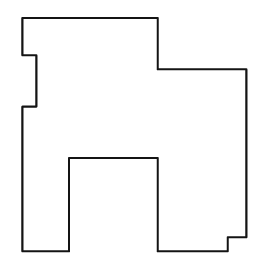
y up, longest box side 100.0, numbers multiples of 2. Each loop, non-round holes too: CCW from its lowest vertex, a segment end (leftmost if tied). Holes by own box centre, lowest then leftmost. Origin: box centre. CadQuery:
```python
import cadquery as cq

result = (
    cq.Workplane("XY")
    .moveTo(-48.0, -50.0)
    .lineTo(-28.0, -50.0)
    .lineTo(-28.0, -10.0)
    .lineTo(10.0, -10.0)
    .lineTo(10.0, -50.0)
    .lineTo(40.0, -50.0)
    .lineTo(40.0, -44.0)
    .lineTo(48.0, -44.0)
    .lineTo(48.0, 28.0)
    .lineTo(10.0, 28.0)
    .lineTo(10.0, 50.0)
    .lineTo(-48.0, 50.0)
    .lineTo(-48.0, 34.0)
    .lineTo(-42.0, 34.0)
    .lineTo(-42.0, 12.0)
    .lineTo(-48.0, 12.0)
    .close()
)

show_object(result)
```